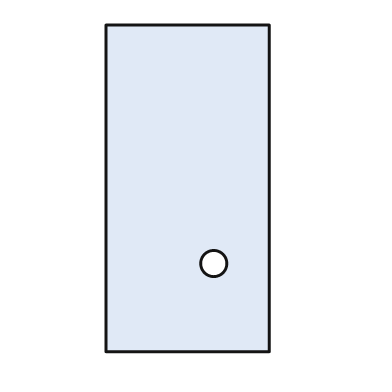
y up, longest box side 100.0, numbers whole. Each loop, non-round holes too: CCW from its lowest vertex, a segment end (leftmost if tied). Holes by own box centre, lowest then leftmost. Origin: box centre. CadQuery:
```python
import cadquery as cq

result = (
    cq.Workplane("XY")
    .moveTo(-25.0, -50.0)
    .lineTo(25.0, -50.0)
    .lineTo(25.0, 50.0)
    .lineTo(-25.0, 50.0)
    .close()
    .moveTo(8.0, -23.0)
    .circle(4.0)
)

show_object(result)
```